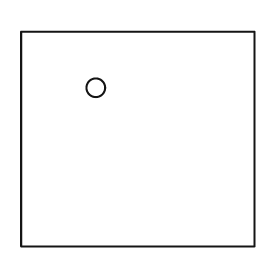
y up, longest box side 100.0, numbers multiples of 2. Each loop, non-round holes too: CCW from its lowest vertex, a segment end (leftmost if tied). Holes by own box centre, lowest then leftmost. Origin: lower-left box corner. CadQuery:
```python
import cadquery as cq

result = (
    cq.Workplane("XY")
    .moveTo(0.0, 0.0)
    .lineTo(100.0, 0.0)
    .lineTo(100.0, 92.0)
    .lineTo(0.0, 92.0)
    .close()
    .moveTo(32.0, 68.0)
    .circle(4.0)
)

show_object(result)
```